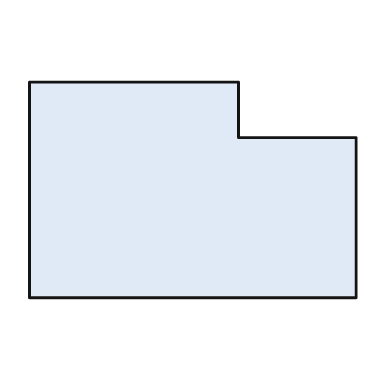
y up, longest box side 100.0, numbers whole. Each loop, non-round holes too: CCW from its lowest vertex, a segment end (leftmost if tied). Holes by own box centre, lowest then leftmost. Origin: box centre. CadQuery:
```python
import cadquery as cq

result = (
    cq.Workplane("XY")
    .moveTo(-50.0, -33.0)
    .lineTo(50.0, -33.0)
    .lineTo(50.0, 16.0)
    .lineTo(14.0, 16.0)
    .lineTo(14.0, 33.0)
    .lineTo(-50.0, 33.0)
    .close()
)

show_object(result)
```